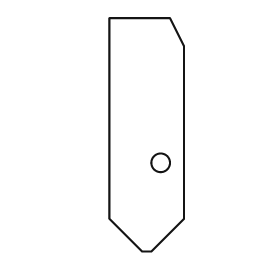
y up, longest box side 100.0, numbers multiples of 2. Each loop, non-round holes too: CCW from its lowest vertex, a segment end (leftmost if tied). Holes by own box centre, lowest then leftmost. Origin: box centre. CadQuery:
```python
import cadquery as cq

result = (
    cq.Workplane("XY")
    .moveTo(-2.0, -50.0)
    .lineTo(2.0, -50.0)
    .lineTo(16.0, -36.0)
    .lineTo(16.0, 38.0)
    .lineTo(10.0, 50.0)
    .lineTo(-16.0, 50.0)
    .lineTo(-16.0, -36.0)
    .close()
    .moveTo(6.0, -12.0)
    .circle(4.0)
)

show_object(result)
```